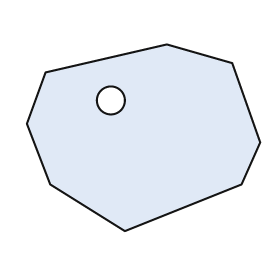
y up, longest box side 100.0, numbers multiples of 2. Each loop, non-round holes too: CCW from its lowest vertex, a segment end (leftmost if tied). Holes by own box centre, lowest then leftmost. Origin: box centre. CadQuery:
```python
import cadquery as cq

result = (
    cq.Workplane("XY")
    .moveTo(-8.0, -40.0)
    .lineTo(42.0, -20.0)
    .lineTo(50.0, -2.0)
    .lineTo(38.0, 32.0)
    .lineTo(10.0, 40.0)
    .lineTo(-42.0, 28.0)
    .lineTo(-50.0, 6.0)
    .lineTo(-40.0, -20.0)
    .close()
    .moveTo(-14.0, 16.0)
    .circle(6.0)
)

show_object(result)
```